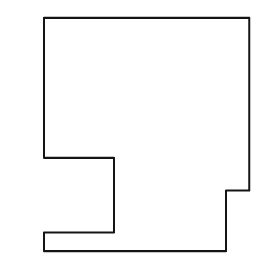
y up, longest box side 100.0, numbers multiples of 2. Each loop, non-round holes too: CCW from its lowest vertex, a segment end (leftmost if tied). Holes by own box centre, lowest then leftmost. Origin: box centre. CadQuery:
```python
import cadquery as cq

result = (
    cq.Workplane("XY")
    .moveTo(-44.0, -50.0)
    .lineTo(34.0, -50.0)
    .lineTo(34.0, -24.0)
    .lineTo(44.0, -24.0)
    .lineTo(44.0, 50.0)
    .lineTo(-44.0, 50.0)
    .lineTo(-44.0, -10.0)
    .lineTo(-14.0, -10.0)
    .lineTo(-14.0, -42.0)
    .lineTo(-44.0, -42.0)
    .close()
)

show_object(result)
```